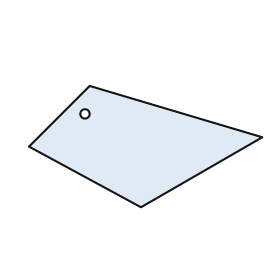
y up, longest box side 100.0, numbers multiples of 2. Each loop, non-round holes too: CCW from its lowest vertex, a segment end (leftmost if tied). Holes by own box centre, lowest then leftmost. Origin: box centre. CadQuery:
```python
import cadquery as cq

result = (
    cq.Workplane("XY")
    .moveTo(-2.0, -26.0)
    .lineTo(50.0, 4.0)
    .lineTo(-24.0, 26.0)
    .lineTo(-50.0, 0.0)
    .close()
    .moveTo(-26.0, 14.0)
    .circle(2.0)
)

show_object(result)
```